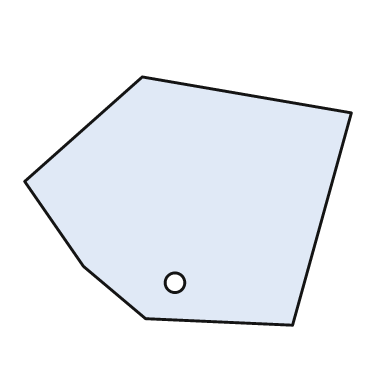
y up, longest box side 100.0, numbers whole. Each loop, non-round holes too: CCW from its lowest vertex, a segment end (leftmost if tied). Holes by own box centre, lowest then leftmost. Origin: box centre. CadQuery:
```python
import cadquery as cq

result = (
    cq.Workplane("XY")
    .moveTo(32.0, -38.0)
    .lineTo(50.0, 27.0)
    .lineTo(-14.0, 38.0)
    .lineTo(-50.0, 6.0)
    .lineTo(-32.0, -20.0)
    .lineTo(-13.0, -36.0)
    .close()
    .moveTo(-4.0, -25.0)
    .circle(3.0)
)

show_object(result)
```